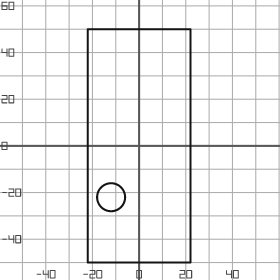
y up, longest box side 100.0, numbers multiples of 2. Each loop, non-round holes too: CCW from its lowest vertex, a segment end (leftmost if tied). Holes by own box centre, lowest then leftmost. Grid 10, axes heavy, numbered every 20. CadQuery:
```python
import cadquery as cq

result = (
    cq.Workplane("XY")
    .moveTo(-22.0, -50.0)
    .lineTo(22.0, -50.0)
    .lineTo(22.0, 50.0)
    .lineTo(-22.0, 50.0)
    .close()
    .moveTo(-12.0, -22.0)
    .circle(6.0)
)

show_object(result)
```